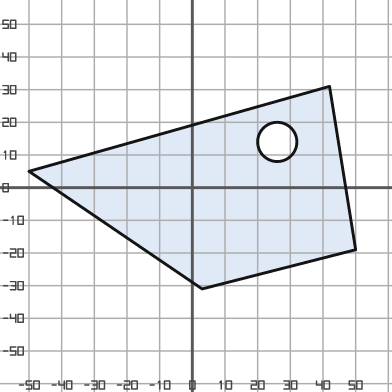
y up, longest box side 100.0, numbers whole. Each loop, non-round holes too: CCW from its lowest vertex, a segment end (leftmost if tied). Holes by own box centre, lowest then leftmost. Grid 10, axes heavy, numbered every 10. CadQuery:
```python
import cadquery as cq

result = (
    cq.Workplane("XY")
    .moveTo(3.0, -31.0)
    .lineTo(50.0, -19.0)
    .lineTo(42.0, 31.0)
    .lineTo(-50.0, 5.0)
    .close()
    .moveTo(26.0, 14.0)
    .circle(6.0)
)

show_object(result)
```